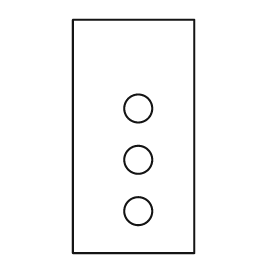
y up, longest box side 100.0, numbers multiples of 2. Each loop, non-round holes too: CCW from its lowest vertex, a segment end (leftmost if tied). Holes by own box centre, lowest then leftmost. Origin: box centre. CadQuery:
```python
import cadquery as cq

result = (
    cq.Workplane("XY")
    .moveTo(-26.0, -50.0)
    .lineTo(26.0, -50.0)
    .lineTo(26.0, 50.0)
    .lineTo(-26.0, 50.0)
    .close()
    .moveTo(2.0, -32.0)
    .circle(6.0)
    .moveTo(2.0, -10.0)
    .circle(6.0)
    .moveTo(2.0, 12.0)
    .circle(6.0)
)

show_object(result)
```